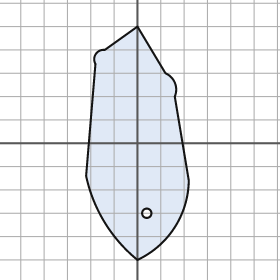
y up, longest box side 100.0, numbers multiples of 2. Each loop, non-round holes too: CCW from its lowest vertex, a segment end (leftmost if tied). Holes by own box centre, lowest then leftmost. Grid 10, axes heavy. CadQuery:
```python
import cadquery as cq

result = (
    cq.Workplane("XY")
    .moveTo(0.0, -50.0)
    .threePointArc((16.0, -36.0), (22.0, -16.0))
    .lineTo(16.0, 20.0)
    .threePointArc((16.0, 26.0), (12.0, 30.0))
    .lineTo(0.0, 50.0)
    .lineTo(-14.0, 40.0)
    .threePointArc((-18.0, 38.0), (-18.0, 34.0))
    .lineTo(-22.0, -14.0)
    .threePointArc((-14.0, -34.0), (0.0, -50.0))
    .close()
    .moveTo(4.0, -30.0)
    .circle(2.0)
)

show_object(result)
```